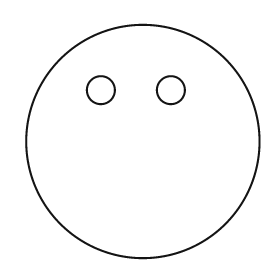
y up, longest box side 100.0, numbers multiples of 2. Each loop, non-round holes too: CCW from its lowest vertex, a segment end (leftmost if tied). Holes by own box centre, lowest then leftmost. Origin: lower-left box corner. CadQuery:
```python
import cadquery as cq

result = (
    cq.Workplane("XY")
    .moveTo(50.0, 50.0)
    .circle(50.0)
    .moveTo(32.0, 72.0)
    .circle(6.0)
    .moveTo(62.0, 72.0)
    .circle(6.0)
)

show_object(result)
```